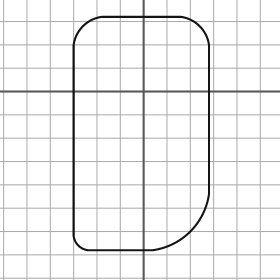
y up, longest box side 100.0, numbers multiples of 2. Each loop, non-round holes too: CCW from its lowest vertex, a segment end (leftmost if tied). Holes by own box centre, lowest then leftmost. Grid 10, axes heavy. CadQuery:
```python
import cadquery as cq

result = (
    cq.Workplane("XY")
    .moveTo(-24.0, -68.0)
    .lineTo(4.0, -68.0)
    .threePointArc((20.0, -60.0), (28.0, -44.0))
    .lineTo(28.0, 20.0)
    .threePointArc((24.0, 28.0), (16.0, 32.0))
    .lineTo(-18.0, 32.0)
    .threePointArc((-26.0, 28.0), (-30.0, 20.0))
    .lineTo(-30.0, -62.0)
    .threePointArc((-28.0, -66.0), (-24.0, -68.0))
    .close()
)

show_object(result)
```